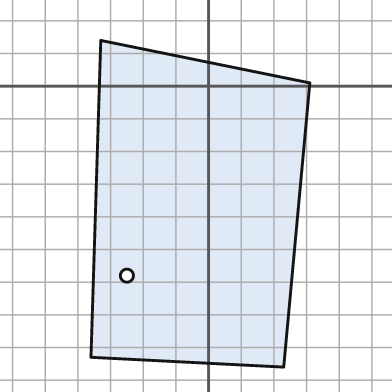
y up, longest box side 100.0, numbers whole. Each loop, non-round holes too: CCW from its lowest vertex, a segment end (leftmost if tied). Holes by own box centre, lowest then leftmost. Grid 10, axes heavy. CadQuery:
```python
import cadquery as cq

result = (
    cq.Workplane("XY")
    .moveTo(23.0, -86.0)
    .lineTo(31.0, 1.0)
    .lineTo(-33.0, 14.0)
    .lineTo(-36.0, -83.0)
    .close()
    .moveTo(-25.0, -58.0)
    .circle(2.0)
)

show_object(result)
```